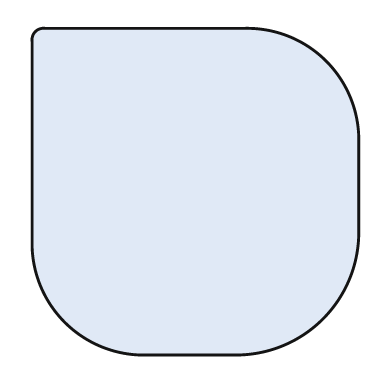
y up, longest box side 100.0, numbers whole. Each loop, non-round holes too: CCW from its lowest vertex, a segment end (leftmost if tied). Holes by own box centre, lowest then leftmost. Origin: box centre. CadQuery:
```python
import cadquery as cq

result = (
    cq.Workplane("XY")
    .moveTo(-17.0, -50.0)
    .lineTo(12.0, -50.0)
    .threePointArc((39.0, -39.0), (50.0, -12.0))
    .lineTo(50.0, 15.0)
    .threePointArc((40.0, 40.0), (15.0, 50.0))
    .lineTo(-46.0, 50.0)
    .threePointArc((-49.0, 49.0), (-50.0, 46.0))
    .lineTo(-50.0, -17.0)
    .threePointArc((-40.0, -40.0), (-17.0, -50.0))
    .close()
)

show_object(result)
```